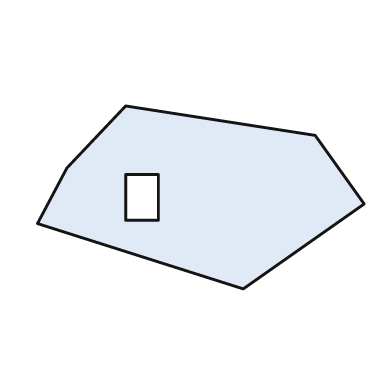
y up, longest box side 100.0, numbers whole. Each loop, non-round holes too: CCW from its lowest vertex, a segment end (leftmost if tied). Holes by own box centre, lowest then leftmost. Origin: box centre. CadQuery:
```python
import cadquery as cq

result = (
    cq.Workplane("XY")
    .moveTo(13.0, -28.0)
    .lineTo(50.0, -2.0)
    .lineTo(35.0, 19.0)
    .lineTo(-23.0, 28.0)
    .lineTo(-41.0, 9.0)
    .lineTo(-50.0, -8.0)
    .close()
    .moveTo(-23.0, -7.0)
    .lineTo(-13.0, -7.0)
    .lineTo(-13.0, 7.0)
    .lineTo(-23.0, 7.0)
    .close()
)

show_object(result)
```